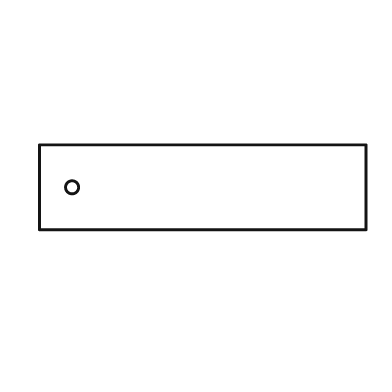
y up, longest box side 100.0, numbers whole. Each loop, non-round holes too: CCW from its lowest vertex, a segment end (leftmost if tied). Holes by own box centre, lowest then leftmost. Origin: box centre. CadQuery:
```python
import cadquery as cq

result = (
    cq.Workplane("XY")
    .moveTo(-50.0, -13.0)
    .lineTo(50.0, -13.0)
    .lineTo(50.0, 13.0)
    .lineTo(-50.0, 13.0)
    .close()
    .moveTo(-40.0, 0.0)
    .circle(2.0)
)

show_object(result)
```